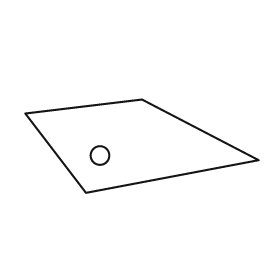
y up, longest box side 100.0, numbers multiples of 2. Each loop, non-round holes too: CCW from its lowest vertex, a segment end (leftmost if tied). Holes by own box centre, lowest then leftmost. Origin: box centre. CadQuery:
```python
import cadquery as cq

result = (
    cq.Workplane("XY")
    .moveTo(-24.0, -20.0)
    .lineTo(50.0, -6.0)
    .lineTo(0.0, 20.0)
    .lineTo(-50.0, 14.0)
    .close()
    .moveTo(-18.0, -4.0)
    .circle(4.0)
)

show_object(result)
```